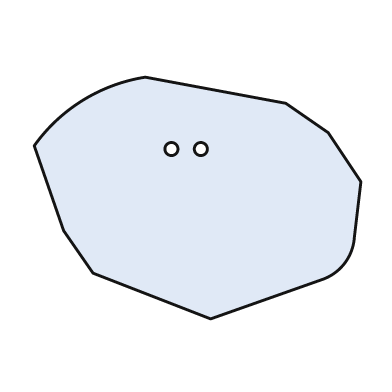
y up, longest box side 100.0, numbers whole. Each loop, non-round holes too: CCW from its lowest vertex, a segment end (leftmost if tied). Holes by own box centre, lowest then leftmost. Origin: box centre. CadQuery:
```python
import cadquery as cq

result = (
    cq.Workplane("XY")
    .moveTo(4.0, -37.0)
    .lineTo(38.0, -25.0)
    .threePointArc((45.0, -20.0), (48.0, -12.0))
    .lineTo(50.0, 5.0)
    .lineTo(40.0, 20.0)
    .lineTo(27.0, 29.0)
    .lineTo(-16.0, 37.0)
    .threePointArc((-35.0, 30.0), (-50.0, 16.0))
    .lineTo(-41.0, -10.0)
    .lineTo(-32.0, -23.0)
    .close()
    .moveTo(-8.0, 15.0)
    .circle(2.0)
    .moveTo(1.0, 15.0)
    .circle(2.0)
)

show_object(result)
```